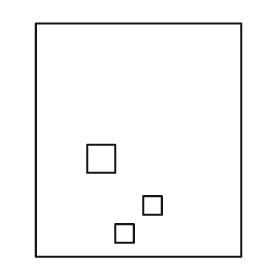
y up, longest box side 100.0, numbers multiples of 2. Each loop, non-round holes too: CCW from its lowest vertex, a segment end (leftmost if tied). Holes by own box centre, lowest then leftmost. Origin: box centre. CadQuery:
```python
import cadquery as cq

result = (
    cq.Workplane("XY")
    .moveTo(-44.0, -50.0)
    .lineTo(44.0, -50.0)
    .lineTo(44.0, 50.0)
    .lineTo(-44.0, 50.0)
    .close()
    .moveTo(-10.0, -44.0)
    .lineTo(-2.0, -44.0)
    .lineTo(-2.0, -36.0)
    .lineTo(-10.0, -36.0)
    .close()
    .moveTo(2.0, -32.0)
    .lineTo(10.0, -32.0)
    .lineTo(10.0, -24.0)
    .lineTo(2.0, -24.0)
    .close()
    .moveTo(-22.0, -14.0)
    .lineTo(-10.0, -14.0)
    .lineTo(-10.0, -2.0)
    .lineTo(-22.0, -2.0)
    .close()
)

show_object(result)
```